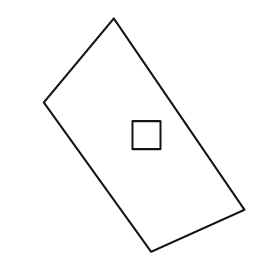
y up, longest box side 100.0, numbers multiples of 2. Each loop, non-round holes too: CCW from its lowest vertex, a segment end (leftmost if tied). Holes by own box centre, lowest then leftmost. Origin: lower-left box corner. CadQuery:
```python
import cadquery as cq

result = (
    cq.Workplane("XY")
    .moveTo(46.0, 0.0)
    .lineTo(86.0, 18.0)
    .lineTo(30.0, 100.0)
    .lineTo(0.0, 64.0)
    .close()
    .moveTo(38.0, 44.0)
    .lineTo(50.0, 44.0)
    .lineTo(50.0, 56.0)
    .lineTo(38.0, 56.0)
    .close()
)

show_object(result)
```